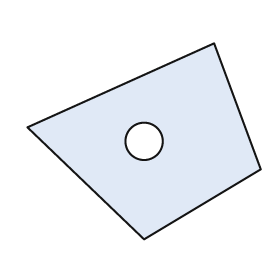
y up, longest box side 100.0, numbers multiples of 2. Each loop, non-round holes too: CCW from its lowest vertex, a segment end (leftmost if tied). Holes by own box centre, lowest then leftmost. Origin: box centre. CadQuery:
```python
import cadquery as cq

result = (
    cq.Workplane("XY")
    .moveTo(0.0, -42.0)
    .lineTo(50.0, -12.0)
    .lineTo(30.0, 42.0)
    .lineTo(-50.0, 6.0)
    .close()
    .moveTo(0.0, 0.0)
    .circle(8.0)
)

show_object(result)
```